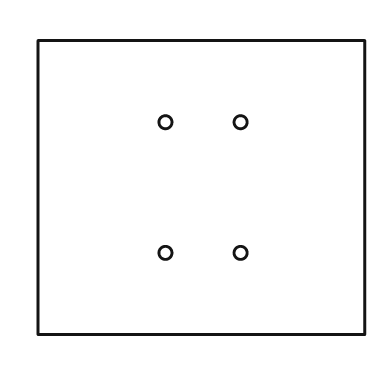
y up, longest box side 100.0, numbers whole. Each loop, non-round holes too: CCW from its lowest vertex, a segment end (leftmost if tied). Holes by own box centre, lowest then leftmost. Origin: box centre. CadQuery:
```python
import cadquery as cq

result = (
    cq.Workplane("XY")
    .moveTo(-50.0, -45.0)
    .lineTo(50.0, -45.0)
    .lineTo(50.0, 45.0)
    .lineTo(-50.0, 45.0)
    .close()
    .moveTo(-11.0, -20.0)
    .circle(2.0)
    .moveTo(12.0, -20.0)
    .circle(2.0)
    .moveTo(-11.0, 20.0)
    .circle(2.0)
    .moveTo(12.0, 20.0)
    .circle(2.0)
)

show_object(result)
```